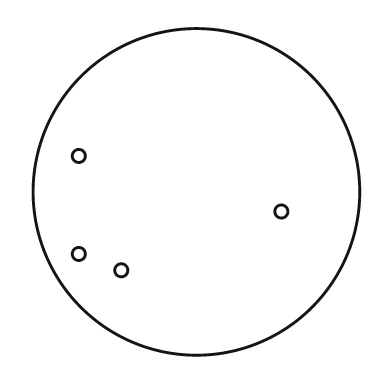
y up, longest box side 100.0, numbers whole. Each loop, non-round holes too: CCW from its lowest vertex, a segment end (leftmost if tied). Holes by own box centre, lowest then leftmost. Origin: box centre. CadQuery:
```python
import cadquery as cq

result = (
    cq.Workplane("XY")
    .moveTo(0.0, 0.0)
    .circle(50.0)
    .moveTo(-23.0, -24.0)
    .circle(2.0)
    .moveTo(-36.0, -19.0)
    .circle(2.0)
    .moveTo(26.0, -6.0)
    .circle(2.0)
    .moveTo(-36.0, 11.0)
    .circle(2.0)
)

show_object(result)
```